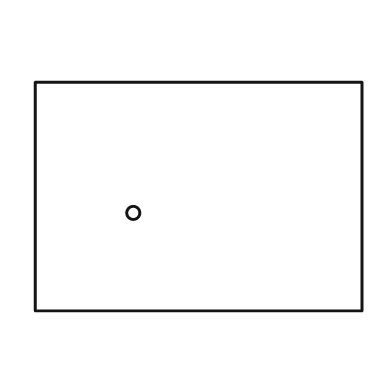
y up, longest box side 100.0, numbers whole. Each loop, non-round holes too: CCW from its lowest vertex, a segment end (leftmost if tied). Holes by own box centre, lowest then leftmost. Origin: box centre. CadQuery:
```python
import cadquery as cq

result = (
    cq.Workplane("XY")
    .moveTo(-50.0, -35.0)
    .lineTo(50.0, -35.0)
    .lineTo(50.0, 35.0)
    .lineTo(-50.0, 35.0)
    .close()
    .moveTo(-20.0, -5.0)
    .circle(2.0)
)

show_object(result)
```